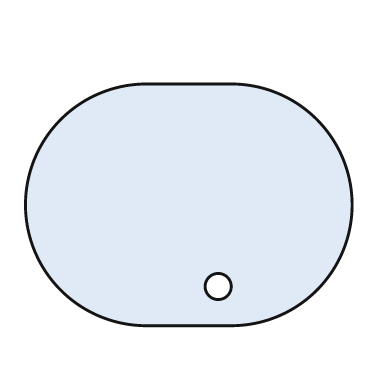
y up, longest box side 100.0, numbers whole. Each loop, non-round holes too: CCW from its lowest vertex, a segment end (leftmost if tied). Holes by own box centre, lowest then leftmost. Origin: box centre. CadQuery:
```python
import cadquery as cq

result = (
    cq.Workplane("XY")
    .moveTo(-13.0, -37.0)
    .lineTo(13.0, -37.0)
    .threePointArc((50.0, 0.0), (13.0, 37.0))
    .lineTo(-13.0, 37.0)
    .threePointArc((-50.0, 0.0), (-13.0, -37.0))
    .close()
    .moveTo(9.0, -25.0)
    .circle(4.0)
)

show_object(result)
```